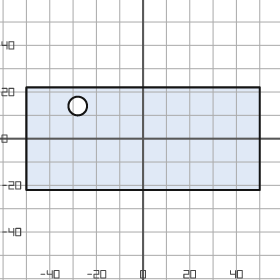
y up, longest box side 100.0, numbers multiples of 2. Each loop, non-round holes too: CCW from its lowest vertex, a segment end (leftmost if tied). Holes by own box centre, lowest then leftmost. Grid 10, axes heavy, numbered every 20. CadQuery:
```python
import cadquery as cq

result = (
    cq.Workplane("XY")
    .moveTo(-50.0, -22.0)
    .lineTo(50.0, -22.0)
    .lineTo(50.0, 22.0)
    .lineTo(-50.0, 22.0)
    .close()
    .moveTo(-28.0, 14.0)
    .circle(4.0)
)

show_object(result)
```